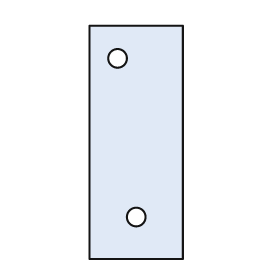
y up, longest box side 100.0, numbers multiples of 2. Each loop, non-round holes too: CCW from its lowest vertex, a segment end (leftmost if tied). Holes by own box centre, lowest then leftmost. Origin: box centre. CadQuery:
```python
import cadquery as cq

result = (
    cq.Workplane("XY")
    .moveTo(-20.0, -50.0)
    .lineTo(20.0, -50.0)
    .lineTo(20.0, 50.0)
    .lineTo(-20.0, 50.0)
    .close()
    .moveTo(0.0, -32.0)
    .circle(4.0)
    .moveTo(-8.0, 36.0)
    .circle(4.0)
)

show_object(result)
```